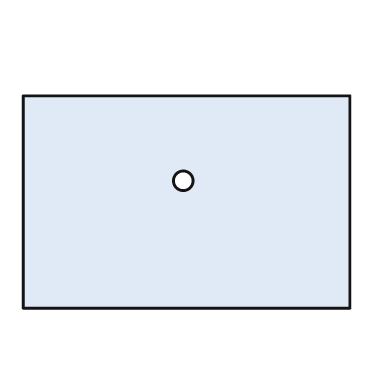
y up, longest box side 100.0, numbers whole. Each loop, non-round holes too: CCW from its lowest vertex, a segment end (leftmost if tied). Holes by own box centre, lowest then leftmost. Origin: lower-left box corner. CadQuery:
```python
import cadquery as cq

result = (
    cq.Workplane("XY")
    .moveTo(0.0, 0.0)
    .lineTo(100.0, 0.0)
    .lineTo(100.0, 65.0)
    .lineTo(0.0, 65.0)
    .close()
    .moveTo(49.0, 39.0)
    .circle(3.0)
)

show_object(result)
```